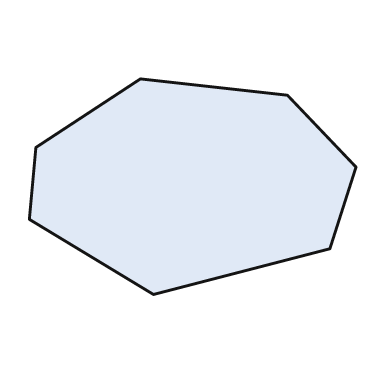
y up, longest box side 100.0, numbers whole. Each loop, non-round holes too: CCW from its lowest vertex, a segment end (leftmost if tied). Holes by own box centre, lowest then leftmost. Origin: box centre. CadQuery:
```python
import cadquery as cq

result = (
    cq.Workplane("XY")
    .moveTo(-12.0, -33.0)
    .lineTo(42.0, -19.0)
    .lineTo(50.0, 6.0)
    .lineTo(29.0, 28.0)
    .lineTo(-16.0, 33.0)
    .lineTo(-48.0, 12.0)
    .lineTo(-50.0, -10.0)
    .close()
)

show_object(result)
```